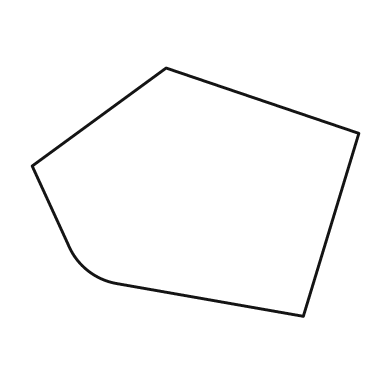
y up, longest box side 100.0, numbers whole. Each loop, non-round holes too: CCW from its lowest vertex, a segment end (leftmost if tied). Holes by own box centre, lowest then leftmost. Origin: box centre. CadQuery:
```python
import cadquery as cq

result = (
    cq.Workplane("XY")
    .moveTo(33.0, -38.0)
    .lineTo(50.0, 18.0)
    .lineTo(-9.0, 38.0)
    .lineTo(-50.0, 8.0)
    .lineTo(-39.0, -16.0)
    .threePointArc((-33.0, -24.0), (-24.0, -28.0))
    .close()
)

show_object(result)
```